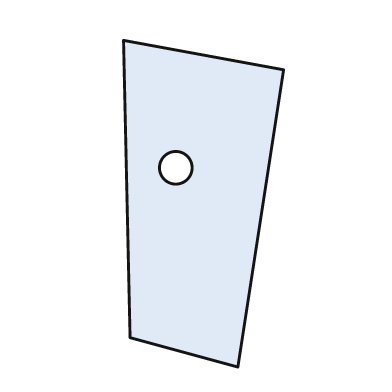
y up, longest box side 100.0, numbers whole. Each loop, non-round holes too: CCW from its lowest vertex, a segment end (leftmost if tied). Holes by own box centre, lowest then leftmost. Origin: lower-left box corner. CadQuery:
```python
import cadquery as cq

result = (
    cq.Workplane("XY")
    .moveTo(35.0, 0.0)
    .lineTo(49.0, 91.0)
    .lineTo(0.0, 100.0)
    .lineTo(2.0, 9.0)
    .close()
    .moveTo(16.0, 61.0)
    .circle(5.0)
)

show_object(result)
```